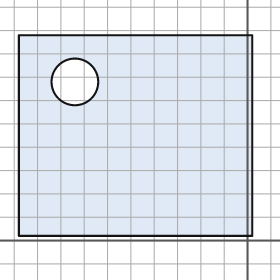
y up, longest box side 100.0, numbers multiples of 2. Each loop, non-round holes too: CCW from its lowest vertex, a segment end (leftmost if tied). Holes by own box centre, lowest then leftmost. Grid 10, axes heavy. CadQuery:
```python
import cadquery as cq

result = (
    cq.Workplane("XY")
    .moveTo(-98.0, 2.0)
    .lineTo(2.0, 2.0)
    .lineTo(2.0, 88.0)
    .lineTo(-98.0, 88.0)
    .close()
    .moveTo(-74.0, 68.0)
    .circle(10.0)
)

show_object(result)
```